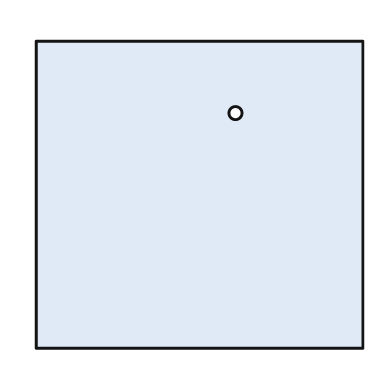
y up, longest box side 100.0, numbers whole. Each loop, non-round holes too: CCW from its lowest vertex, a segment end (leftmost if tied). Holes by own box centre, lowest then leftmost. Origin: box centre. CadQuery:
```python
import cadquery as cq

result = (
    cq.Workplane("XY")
    .moveTo(-50.0, -47.0)
    .lineTo(50.0, -47.0)
    .lineTo(50.0, 47.0)
    .lineTo(-50.0, 47.0)
    .close()
    .moveTo(11.0, 25.0)
    .circle(2.0)
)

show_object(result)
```